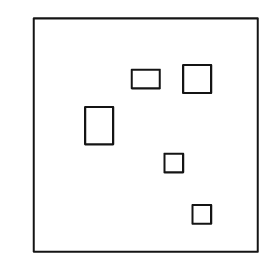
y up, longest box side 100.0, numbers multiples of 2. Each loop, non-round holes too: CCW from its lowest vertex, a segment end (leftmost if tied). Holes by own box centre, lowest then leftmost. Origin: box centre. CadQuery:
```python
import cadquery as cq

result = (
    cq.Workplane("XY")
    .moveTo(-48.0, -50.0)
    .lineTo(48.0, -50.0)
    .lineTo(48.0, 50.0)
    .lineTo(-48.0, 50.0)
    .close()
    .moveTo(20.0, -38.0)
    .lineTo(28.0, -38.0)
    .lineTo(28.0, -30.0)
    .lineTo(20.0, -30.0)
    .close()
    .moveTo(8.0, -16.0)
    .lineTo(16.0, -16.0)
    .lineTo(16.0, -8.0)
    .lineTo(8.0, -8.0)
    .close()
    .moveTo(-26.0, -4.0)
    .lineTo(-14.0, -4.0)
    .lineTo(-14.0, 12.0)
    .lineTo(-26.0, 12.0)
    .close()
    .moveTo(-6.0, 20.0)
    .lineTo(6.0, 20.0)
    .lineTo(6.0, 28.0)
    .lineTo(-6.0, 28.0)
    .close()
    .moveTo(16.0, 18.0)
    .lineTo(28.0, 18.0)
    .lineTo(28.0, 30.0)
    .lineTo(16.0, 30.0)
    .close()
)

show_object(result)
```